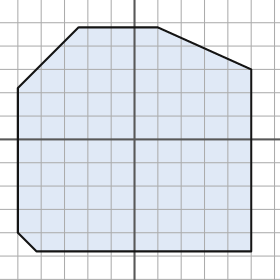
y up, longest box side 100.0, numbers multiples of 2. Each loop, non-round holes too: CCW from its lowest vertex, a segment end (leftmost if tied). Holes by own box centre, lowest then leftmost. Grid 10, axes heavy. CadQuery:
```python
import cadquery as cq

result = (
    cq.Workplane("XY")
    .moveTo(-42.0, -48.0)
    .lineTo(50.0, -48.0)
    .lineTo(50.0, 30.0)
    .lineTo(10.0, 48.0)
    .lineTo(-24.0, 48.0)
    .lineTo(-50.0, 22.0)
    .lineTo(-50.0, -40.0)
    .close()
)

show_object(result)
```